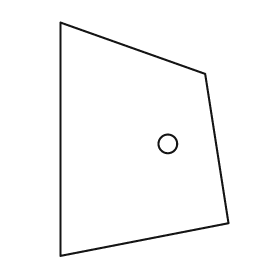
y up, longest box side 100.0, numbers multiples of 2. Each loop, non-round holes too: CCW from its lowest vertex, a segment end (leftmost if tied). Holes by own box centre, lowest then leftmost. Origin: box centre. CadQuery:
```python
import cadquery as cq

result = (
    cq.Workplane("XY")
    .moveTo(-36.0, -50.0)
    .lineTo(36.0, -36.0)
    .lineTo(26.0, 28.0)
    .lineTo(-36.0, 50.0)
    .close()
    .moveTo(10.0, -2.0)
    .circle(4.0)
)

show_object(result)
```